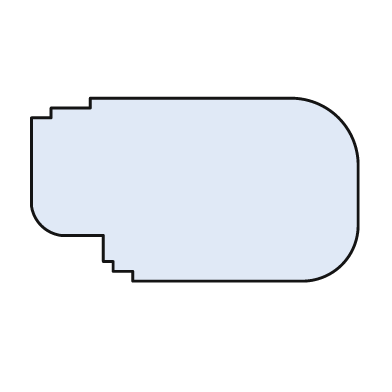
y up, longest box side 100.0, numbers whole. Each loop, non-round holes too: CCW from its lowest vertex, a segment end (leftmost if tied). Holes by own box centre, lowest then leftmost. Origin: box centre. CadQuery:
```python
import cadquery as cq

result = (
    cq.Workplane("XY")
    .moveTo(-19.0, -28.0)
    .lineTo(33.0, -28.0)
    .threePointArc((45.0, -23.0), (50.0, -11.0))
    .lineTo(50.0, 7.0)
    .threePointArc((44.0, 22.0), (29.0, 28.0))
    .lineTo(-32.0, 28.0)
    .lineTo(-32.0, 25.0)
    .lineTo(-44.0, 25.0)
    .lineTo(-44.0, 22.0)
    .lineTo(-50.0, 22.0)
    .lineTo(-50.0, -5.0)
    .threePointArc((-47.0, -11.0), (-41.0, -14.0))
    .lineTo(-28.0, -14.0)
    .lineTo(-28.0, -22.0)
    .lineTo(-25.0, -22.0)
    .lineTo(-25.0, -25.0)
    .lineTo(-19.0, -25.0)
    .close()
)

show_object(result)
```